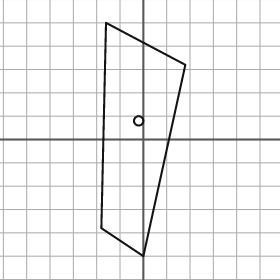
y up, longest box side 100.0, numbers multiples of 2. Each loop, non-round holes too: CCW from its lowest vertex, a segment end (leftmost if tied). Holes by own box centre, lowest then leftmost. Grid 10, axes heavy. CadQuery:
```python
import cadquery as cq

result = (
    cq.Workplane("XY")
    .moveTo(0.0, -50.0)
    .lineTo(18.0, 32.0)
    .lineTo(-16.0, 50.0)
    .lineTo(-18.0, -38.0)
    .close()
    .moveTo(-2.0, 8.0)
    .circle(2.0)
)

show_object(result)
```